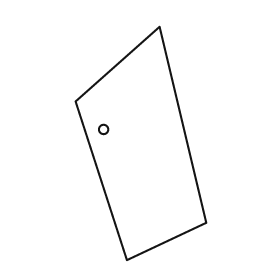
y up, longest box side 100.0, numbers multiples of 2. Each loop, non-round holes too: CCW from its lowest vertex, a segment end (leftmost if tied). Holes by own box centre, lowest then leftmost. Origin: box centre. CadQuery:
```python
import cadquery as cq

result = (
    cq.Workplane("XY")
    .moveTo(-6.0, -50.0)
    .lineTo(28.0, -34.0)
    .lineTo(8.0, 50.0)
    .lineTo(-28.0, 18.0)
    .close()
    .moveTo(-16.0, 6.0)
    .circle(2.0)
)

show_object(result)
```